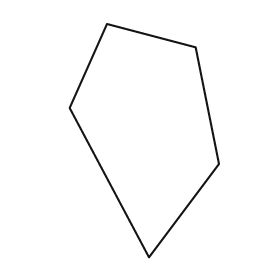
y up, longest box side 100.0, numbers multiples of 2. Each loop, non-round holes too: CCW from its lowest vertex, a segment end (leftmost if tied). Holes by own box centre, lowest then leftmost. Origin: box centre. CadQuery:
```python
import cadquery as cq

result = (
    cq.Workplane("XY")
    .moveTo(2.0, -50.0)
    .lineTo(32.0, -10.0)
    .lineTo(22.0, 40.0)
    .lineTo(-16.0, 50.0)
    .lineTo(-32.0, 14.0)
    .close()
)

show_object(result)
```